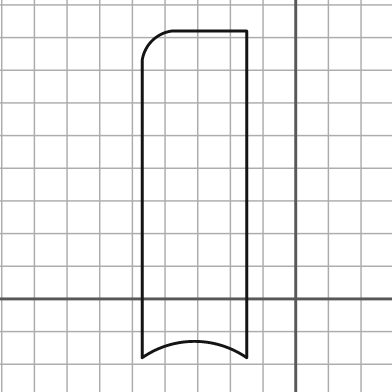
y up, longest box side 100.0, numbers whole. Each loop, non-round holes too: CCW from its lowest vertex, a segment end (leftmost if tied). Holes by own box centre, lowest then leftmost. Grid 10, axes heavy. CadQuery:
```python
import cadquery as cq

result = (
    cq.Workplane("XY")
    .moveTo(-47.0, -18.0)
    .threePointArc((-31.0, -13.0), (-15.0, -18.0))
    .lineTo(-15.0, 82.0)
    .lineTo(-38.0, 82.0)
    .threePointArc((-44.0, 79.0), (-47.0, 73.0))
    .close()
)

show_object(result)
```